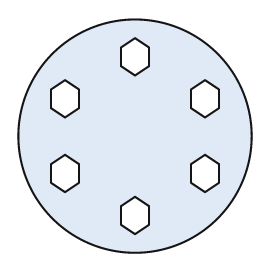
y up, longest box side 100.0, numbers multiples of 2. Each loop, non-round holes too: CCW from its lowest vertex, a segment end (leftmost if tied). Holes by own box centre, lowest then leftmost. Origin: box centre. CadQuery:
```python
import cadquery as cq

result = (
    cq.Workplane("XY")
    .moveTo(0.0, 0.0)
    .circle(50.0)
    .moveTo(0.0, -42.0)
    .lineTo(6.0, -38.0)
    .lineTo(6.0, -30.0)
    .lineTo(0.0, -26.0)
    .lineTo(-6.0, -30.0)
    .lineTo(-6.0, -38.0)
    .close()
    .moveTo(-30.0, -24.0)
    .lineTo(-24.0, -20.0)
    .lineTo(-24.0, -12.0)
    .lineTo(-30.0, -8.0)
    .lineTo(-36.0, -12.0)
    .lineTo(-36.0, -20.0)
    .close()
    .moveTo(30.0, -24.0)
    .lineTo(36.0, -20.0)
    .lineTo(36.0, -12.0)
    .lineTo(30.0, -8.0)
    .lineTo(24.0, -12.0)
    .lineTo(24.0, -20.0)
    .close()
    .moveTo(-30.0, 8.0)
    .lineTo(-24.0, 12.0)
    .lineTo(-24.0, 20.0)
    .lineTo(-30.0, 24.0)
    .lineTo(-36.0, 20.0)
    .lineTo(-36.0, 12.0)
    .close()
    .moveTo(30.0, 8.0)
    .lineTo(36.0, 12.0)
    .lineTo(36.0, 20.0)
    .lineTo(30.0, 24.0)
    .lineTo(24.0, 20.0)
    .lineTo(24.0, 12.0)
    .close()
    .moveTo(0.0, 26.0)
    .lineTo(6.0, 30.0)
    .lineTo(6.0, 38.0)
    .lineTo(0.0, 42.0)
    .lineTo(-6.0, 38.0)
    .lineTo(-6.0, 30.0)
    .close()
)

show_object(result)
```